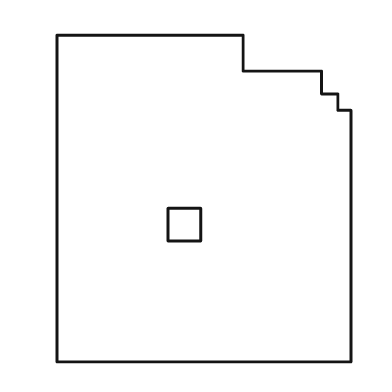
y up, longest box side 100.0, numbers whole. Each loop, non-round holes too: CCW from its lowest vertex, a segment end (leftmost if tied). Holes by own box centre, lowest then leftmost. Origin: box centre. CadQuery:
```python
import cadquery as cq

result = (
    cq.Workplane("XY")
    .moveTo(-45.0, -50.0)
    .lineTo(45.0, -50.0)
    .lineTo(45.0, 27.0)
    .lineTo(41.0, 27.0)
    .lineTo(41.0, 32.0)
    .lineTo(36.0, 32.0)
    .lineTo(36.0, 39.0)
    .lineTo(12.0, 39.0)
    .lineTo(12.0, 50.0)
    .lineTo(-45.0, 50.0)
    .close()
    .moveTo(-11.0, -13.0)
    .lineTo(-1.0, -13.0)
    .lineTo(-1.0, -3.0)
    .lineTo(-11.0, -3.0)
    .close()
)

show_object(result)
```